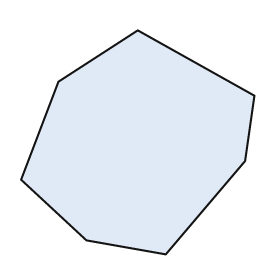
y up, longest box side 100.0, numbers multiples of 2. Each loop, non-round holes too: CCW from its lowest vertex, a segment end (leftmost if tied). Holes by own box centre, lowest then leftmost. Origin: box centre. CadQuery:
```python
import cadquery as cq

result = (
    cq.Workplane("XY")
    .moveTo(12.0, -48.0)
    .lineTo(46.0, -8.0)
    .lineTo(50.0, 20.0)
    .lineTo(0.0, 48.0)
    .lineTo(-34.0, 26.0)
    .lineTo(-50.0, -16.0)
    .lineTo(-22.0, -42.0)
    .close()
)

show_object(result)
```